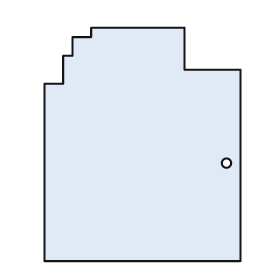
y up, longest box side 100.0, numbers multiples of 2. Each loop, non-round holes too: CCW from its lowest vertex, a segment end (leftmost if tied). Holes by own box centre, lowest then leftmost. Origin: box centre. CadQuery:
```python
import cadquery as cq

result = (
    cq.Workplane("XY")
    .moveTo(-42.0, -50.0)
    .lineTo(42.0, -50.0)
    .lineTo(42.0, 32.0)
    .lineTo(18.0, 32.0)
    .lineTo(18.0, 50.0)
    .lineTo(-22.0, 50.0)
    .lineTo(-22.0, 46.0)
    .lineTo(-30.0, 46.0)
    .lineTo(-30.0, 38.0)
    .lineTo(-34.0, 38.0)
    .lineTo(-34.0, 26.0)
    .lineTo(-42.0, 26.0)
    .close()
    .moveTo(36.0, -8.0)
    .circle(2.0)
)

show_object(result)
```